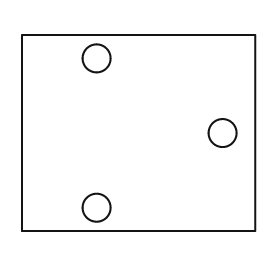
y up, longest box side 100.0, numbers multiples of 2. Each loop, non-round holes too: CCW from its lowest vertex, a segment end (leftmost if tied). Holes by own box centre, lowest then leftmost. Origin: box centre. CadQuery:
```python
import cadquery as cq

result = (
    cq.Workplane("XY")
    .moveTo(-50.0, -42.0)
    .lineTo(50.0, -42.0)
    .lineTo(50.0, 42.0)
    .lineTo(-50.0, 42.0)
    .close()
    .moveTo(-18.0, -32.0)
    .circle(6.0)
    .moveTo(36.0, 0.0)
    .circle(6.0)
    .moveTo(-18.0, 32.0)
    .circle(6.0)
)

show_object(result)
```